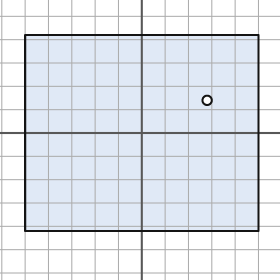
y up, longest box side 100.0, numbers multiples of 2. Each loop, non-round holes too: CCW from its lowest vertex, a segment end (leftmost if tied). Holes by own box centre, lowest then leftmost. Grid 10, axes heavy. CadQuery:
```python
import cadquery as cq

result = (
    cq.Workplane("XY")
    .moveTo(-50.0, -42.0)
    .lineTo(50.0, -42.0)
    .lineTo(50.0, 42.0)
    .lineTo(-50.0, 42.0)
    .close()
    .moveTo(28.0, 14.0)
    .circle(2.0)
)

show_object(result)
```